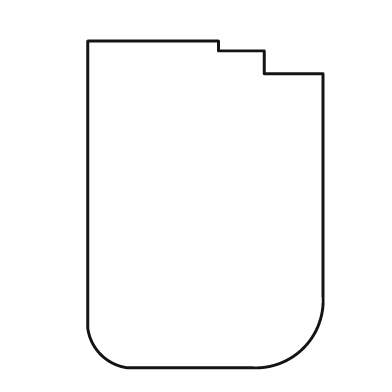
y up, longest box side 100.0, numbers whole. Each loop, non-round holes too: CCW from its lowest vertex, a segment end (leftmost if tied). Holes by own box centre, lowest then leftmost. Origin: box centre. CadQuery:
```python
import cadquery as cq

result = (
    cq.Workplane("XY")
    .moveTo(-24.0, -50.0)
    .lineTo(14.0, -50.0)
    .threePointArc((30.0, -44.0), (36.0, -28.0))
    .lineTo(36.0, 40.0)
    .lineTo(18.0, 40.0)
    .lineTo(18.0, 47.0)
    .lineTo(4.0, 47.0)
    .lineTo(4.0, 50.0)
    .lineTo(-36.0, 50.0)
    .lineTo(-36.0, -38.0)
    .threePointArc((-32.0, -46.0), (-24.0, -50.0))
    .close()
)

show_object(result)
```